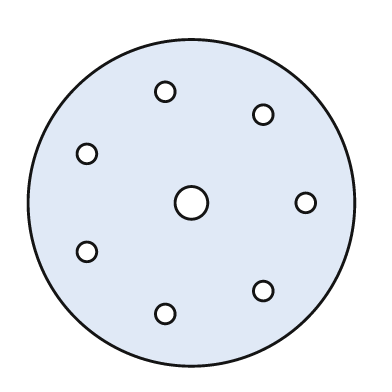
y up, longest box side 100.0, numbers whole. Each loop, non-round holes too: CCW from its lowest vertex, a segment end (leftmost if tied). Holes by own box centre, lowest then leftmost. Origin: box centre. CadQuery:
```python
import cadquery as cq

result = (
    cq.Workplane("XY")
    .moveTo(0.0, 0.0)
    .circle(50.0)
    .moveTo(-8.0, -34.0)
    .circle(3.0)
    .moveTo(22.0, -27.0)
    .circle(3.0)
    .moveTo(-32.0, -15.0)
    .circle(3.0)
    .moveTo(0.0, 0.0)
    .circle(5.0)
    .moveTo(35.0, 0.0)
    .circle(3.0)
    .moveTo(-32.0, 15.0)
    .circle(3.0)
    .moveTo(22.0, 27.0)
    .circle(3.0)
    .moveTo(-8.0, 34.0)
    .circle(3.0)
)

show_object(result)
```